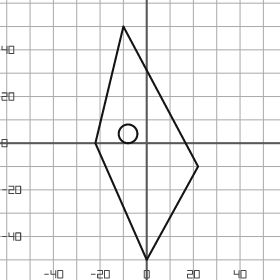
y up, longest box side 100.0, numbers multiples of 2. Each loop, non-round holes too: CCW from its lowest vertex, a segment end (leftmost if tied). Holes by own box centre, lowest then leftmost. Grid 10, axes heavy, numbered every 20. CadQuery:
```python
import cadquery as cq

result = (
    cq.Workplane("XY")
    .moveTo(0.0, -50.0)
    .lineTo(22.0, -10.0)
    .lineTo(-10.0, 50.0)
    .lineTo(-22.0, 0.0)
    .close()
    .moveTo(-8.0, 4.0)
    .circle(4.0)
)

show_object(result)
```